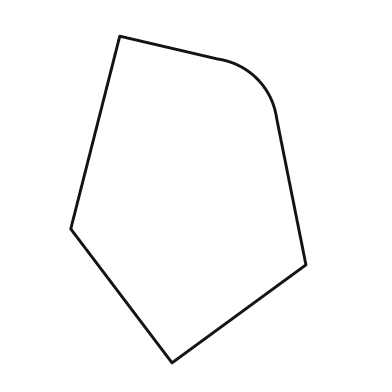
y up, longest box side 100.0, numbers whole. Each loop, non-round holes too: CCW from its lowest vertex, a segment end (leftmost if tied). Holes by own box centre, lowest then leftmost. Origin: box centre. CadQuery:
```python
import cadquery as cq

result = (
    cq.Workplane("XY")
    .moveTo(-5.0, -50.0)
    .lineTo(36.0, -20.0)
    .lineTo(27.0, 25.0)
    .threePointArc((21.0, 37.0), (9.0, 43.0))
    .lineTo(-21.0, 50.0)
    .lineTo(-36.0, -9.0)
    .close()
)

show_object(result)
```